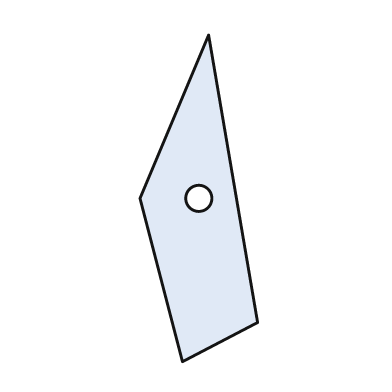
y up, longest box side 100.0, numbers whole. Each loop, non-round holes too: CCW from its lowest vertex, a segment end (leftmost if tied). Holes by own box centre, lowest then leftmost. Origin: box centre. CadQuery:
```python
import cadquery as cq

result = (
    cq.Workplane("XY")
    .moveTo(-5.0, -50.0)
    .lineTo(18.0, -38.0)
    .lineTo(3.0, 50.0)
    .lineTo(-18.0, 0.0)
    .close()
    .moveTo(0.0, 0.0)
    .circle(4.0)
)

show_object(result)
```